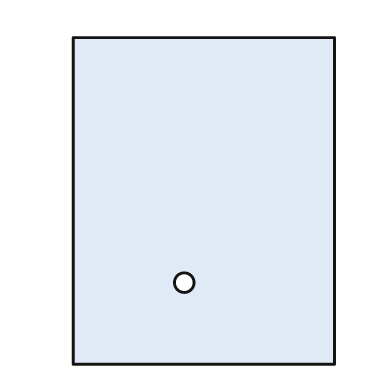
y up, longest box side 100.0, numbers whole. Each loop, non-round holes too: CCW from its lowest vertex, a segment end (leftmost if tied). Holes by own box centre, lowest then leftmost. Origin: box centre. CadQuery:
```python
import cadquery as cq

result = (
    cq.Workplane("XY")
    .moveTo(-40.0, -50.0)
    .lineTo(40.0, -50.0)
    .lineTo(40.0, 50.0)
    .lineTo(-40.0, 50.0)
    .close()
    .moveTo(-6.0, -25.0)
    .circle(3.0)
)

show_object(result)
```